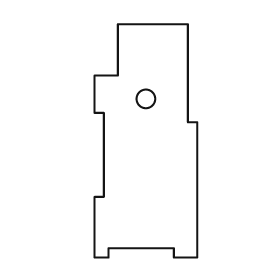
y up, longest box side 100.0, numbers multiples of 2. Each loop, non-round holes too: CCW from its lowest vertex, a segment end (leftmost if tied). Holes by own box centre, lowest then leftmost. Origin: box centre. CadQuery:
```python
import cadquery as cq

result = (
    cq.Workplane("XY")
    .moveTo(-22.0, -50.0)
    .lineTo(-16.0, -50.0)
    .lineTo(-16.0, -46.0)
    .lineTo(12.0, -46.0)
    .lineTo(12.0, -50.0)
    .lineTo(22.0, -50.0)
    .lineTo(22.0, 8.0)
    .lineTo(18.0, 8.0)
    .lineTo(18.0, 50.0)
    .lineTo(-12.0, 50.0)
    .lineTo(-12.0, 28.0)
    .lineTo(-22.0, 28.0)
    .lineTo(-22.0, 12.0)
    .lineTo(-18.0, 12.0)
    .lineTo(-18.0, -24.0)
    .lineTo(-22.0, -24.0)
    .close()
    .moveTo(0.0, 18.0)
    .circle(4.0)
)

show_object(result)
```